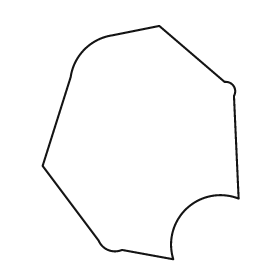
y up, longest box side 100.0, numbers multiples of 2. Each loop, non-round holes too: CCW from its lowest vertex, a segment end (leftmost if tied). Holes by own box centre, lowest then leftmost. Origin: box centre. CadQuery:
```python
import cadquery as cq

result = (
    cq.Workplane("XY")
    .moveTo(14.0, -50.0)
    .threePointArc((20.0, -28.0), (42.0, -24.0))
    .lineTo(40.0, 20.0)
    .threePointArc((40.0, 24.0), (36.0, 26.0))
    .lineTo(8.0, 50.0)
    .lineTo(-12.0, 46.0)
    .threePointArc((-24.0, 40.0), (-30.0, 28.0))
    .lineTo(-42.0, -10.0)
    .lineTo(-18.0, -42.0)
    .threePointArc((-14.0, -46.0), (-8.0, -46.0))
    .close()
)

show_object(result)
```